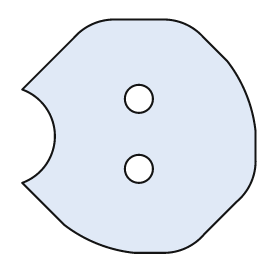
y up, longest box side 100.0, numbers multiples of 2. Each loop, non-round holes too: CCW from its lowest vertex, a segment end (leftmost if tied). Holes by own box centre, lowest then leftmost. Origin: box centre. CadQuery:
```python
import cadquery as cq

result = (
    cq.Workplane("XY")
    .moveTo(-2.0, -50.0)
    .lineTo(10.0, -50.0)
    .threePointArc((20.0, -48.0), (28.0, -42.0))
    .lineTo(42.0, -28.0)
    .threePointArc((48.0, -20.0), (50.0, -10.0))
    .lineTo(50.0, 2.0)
    .threePointArc((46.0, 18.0), (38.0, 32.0))
    .lineTo(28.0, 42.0)
    .threePointArc((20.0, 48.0), (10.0, 50.0))
    .lineTo(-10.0, 50.0)
    .threePointArc((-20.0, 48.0), (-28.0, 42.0))
    .lineTo(-50.0, 20.0)
    .threePointArc((-36.0, 0.0), (-50.0, -20.0))
    .lineTo(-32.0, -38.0)
    .threePointArc((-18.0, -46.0), (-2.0, -50.0))
    .close()
    .moveTo(0.0, -14.0)
    .circle(6.0)
    .moveTo(0.0, 16.0)
    .circle(6.0)
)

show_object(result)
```